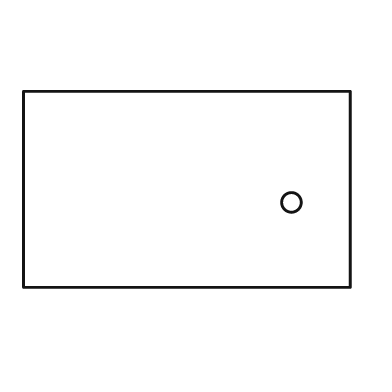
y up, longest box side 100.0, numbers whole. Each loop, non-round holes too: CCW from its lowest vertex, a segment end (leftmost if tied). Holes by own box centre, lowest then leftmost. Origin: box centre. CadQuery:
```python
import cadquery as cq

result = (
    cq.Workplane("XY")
    .moveTo(-50.0, -30.0)
    .lineTo(50.0, -30.0)
    .lineTo(50.0, 30.0)
    .lineTo(-50.0, 30.0)
    .close()
    .moveTo(32.0, -4.0)
    .circle(3.0)
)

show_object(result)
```